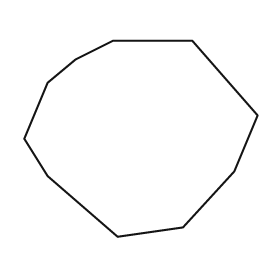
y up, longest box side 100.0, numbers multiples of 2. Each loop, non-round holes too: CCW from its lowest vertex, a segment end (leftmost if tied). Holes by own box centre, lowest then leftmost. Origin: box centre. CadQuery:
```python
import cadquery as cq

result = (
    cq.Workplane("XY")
    .moveTo(-10.0, -42.0)
    .lineTo(18.0, -38.0)
    .lineTo(40.0, -14.0)
    .lineTo(50.0, 10.0)
    .lineTo(22.0, 42.0)
    .lineTo(-12.0, 42.0)
    .lineTo(-28.0, 34.0)
    .lineTo(-40.0, 24.0)
    .lineTo(-50.0, 0.0)
    .lineTo(-40.0, -16.0)
    .close()
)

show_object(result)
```